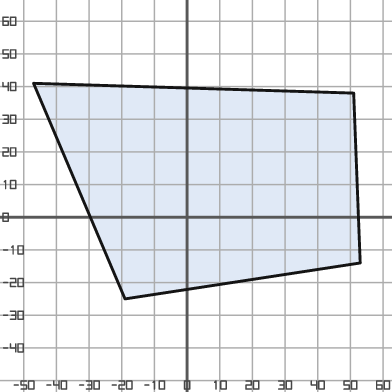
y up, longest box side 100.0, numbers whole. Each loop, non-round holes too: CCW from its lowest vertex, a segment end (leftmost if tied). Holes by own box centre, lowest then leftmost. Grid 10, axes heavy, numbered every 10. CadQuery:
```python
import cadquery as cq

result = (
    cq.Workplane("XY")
    .moveTo(-19.0, -25.0)
    .lineTo(53.0, -14.0)
    .lineTo(51.0, 38.0)
    .lineTo(-47.0, 41.0)
    .close()
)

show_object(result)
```